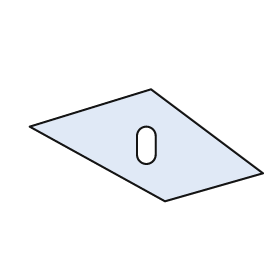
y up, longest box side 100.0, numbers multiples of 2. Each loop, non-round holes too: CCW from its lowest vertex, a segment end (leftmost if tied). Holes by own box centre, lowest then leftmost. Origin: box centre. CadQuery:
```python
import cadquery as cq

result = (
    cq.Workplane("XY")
    .moveTo(8.0, -24.0)
    .lineTo(50.0, -12.0)
    .lineTo(2.0, 24.0)
    .lineTo(-50.0, 8.0)
    .close()
    .moveTo(-4.0, -4.0)
    .threePointArc((0.0, -8.0), (4.0, -4.0))
    .lineTo(4.0, 4.0)
    .threePointArc((0.0, 8.0), (-4.0, 4.0))
    .close()
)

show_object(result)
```